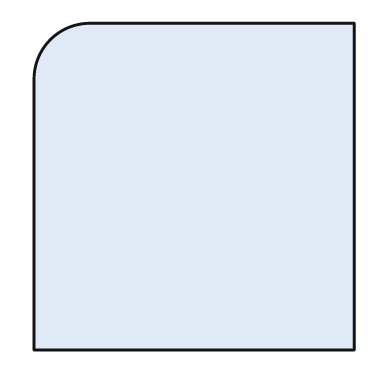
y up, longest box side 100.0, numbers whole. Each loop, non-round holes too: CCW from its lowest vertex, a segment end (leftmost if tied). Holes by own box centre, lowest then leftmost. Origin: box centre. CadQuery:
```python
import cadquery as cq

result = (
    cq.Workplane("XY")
    .moveTo(-49.0, -50.0)
    .lineTo(49.0, -50.0)
    .lineTo(49.0, 50.0)
    .lineTo(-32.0, 50.0)
    .threePointArc((-44.0, 45.0), (-49.0, 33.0))
    .close()
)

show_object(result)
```